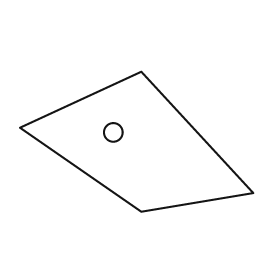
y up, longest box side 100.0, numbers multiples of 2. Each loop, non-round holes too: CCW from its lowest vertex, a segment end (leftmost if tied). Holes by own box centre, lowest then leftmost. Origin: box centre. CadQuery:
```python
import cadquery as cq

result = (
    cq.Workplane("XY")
    .moveTo(2.0, -30.0)
    .lineTo(50.0, -22.0)
    .lineTo(2.0, 30.0)
    .lineTo(-50.0, 6.0)
    .close()
    .moveTo(-10.0, 4.0)
    .circle(4.0)
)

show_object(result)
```